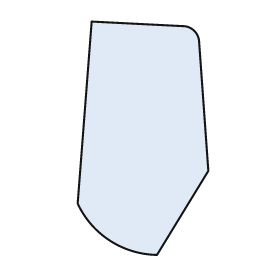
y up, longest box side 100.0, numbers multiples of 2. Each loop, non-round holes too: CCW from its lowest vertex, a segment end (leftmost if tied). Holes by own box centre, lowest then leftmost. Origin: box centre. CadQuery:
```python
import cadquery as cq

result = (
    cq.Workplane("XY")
    .moveTo(6.0, -50.0)
    .lineTo(28.0, -14.0)
    .lineTo(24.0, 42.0)
    .threePointArc((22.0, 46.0), (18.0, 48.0))
    .lineTo(-22.0, 50.0)
    .lineTo(-28.0, -28.0)
    .threePointArc((-14.0, -44.0), (6.0, -50.0))
    .close()
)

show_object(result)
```